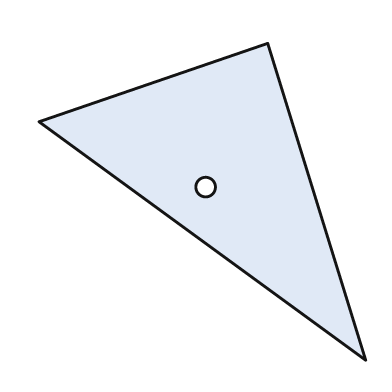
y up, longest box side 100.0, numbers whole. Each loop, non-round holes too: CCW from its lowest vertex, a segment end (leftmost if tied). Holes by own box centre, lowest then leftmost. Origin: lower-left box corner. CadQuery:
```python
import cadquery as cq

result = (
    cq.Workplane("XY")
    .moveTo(100.0, 0.0)
    .lineTo(70.0, 97.0)
    .lineTo(0.0, 73.0)
    .close()
    .moveTo(51.0, 53.0)
    .circle(3.0)
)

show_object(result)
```